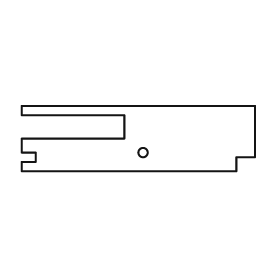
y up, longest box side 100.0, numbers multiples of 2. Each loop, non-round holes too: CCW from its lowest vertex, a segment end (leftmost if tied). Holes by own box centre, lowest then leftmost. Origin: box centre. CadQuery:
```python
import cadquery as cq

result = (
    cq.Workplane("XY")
    .moveTo(-50.0, -14.0)
    .lineTo(42.0, -14.0)
    .lineTo(42.0, -8.0)
    .lineTo(50.0, -8.0)
    .lineTo(50.0, 14.0)
    .lineTo(-50.0, 14.0)
    .lineTo(-50.0, 10.0)
    .lineTo(-6.0, 10.0)
    .lineTo(-6.0, 0.0)
    .lineTo(-50.0, 0.0)
    .lineTo(-50.0, -6.0)
    .lineTo(-44.0, -6.0)
    .lineTo(-44.0, -10.0)
    .lineTo(-50.0, -10.0)
    .close()
    .moveTo(2.0, -6.0)
    .circle(2.0)
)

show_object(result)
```